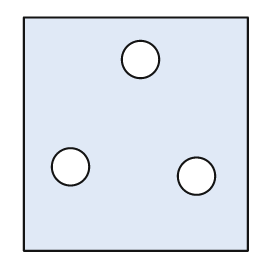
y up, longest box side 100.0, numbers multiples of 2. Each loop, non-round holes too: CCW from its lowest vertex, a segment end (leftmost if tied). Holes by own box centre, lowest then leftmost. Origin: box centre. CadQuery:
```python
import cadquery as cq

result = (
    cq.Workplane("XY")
    .moveTo(-48.0, -50.0)
    .lineTo(48.0, -50.0)
    .lineTo(48.0, 50.0)
    .lineTo(-48.0, 50.0)
    .close()
    .moveTo(26.0, -18.0)
    .circle(8.0)
    .moveTo(-28.0, -14.0)
    .circle(8.0)
    .moveTo(2.0, 32.0)
    .circle(8.0)
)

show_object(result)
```